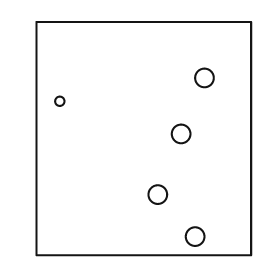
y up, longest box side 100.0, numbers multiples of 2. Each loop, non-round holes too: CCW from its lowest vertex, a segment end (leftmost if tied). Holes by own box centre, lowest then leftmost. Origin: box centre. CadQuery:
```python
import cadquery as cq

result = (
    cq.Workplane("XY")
    .moveTo(-46.0, -50.0)
    .lineTo(46.0, -50.0)
    .lineTo(46.0, 50.0)
    .lineTo(-46.0, 50.0)
    .close()
    .moveTo(22.0, -42.0)
    .circle(4.0)
    .moveTo(6.0, -24.0)
    .circle(4.0)
    .moveTo(16.0, 2.0)
    .circle(4.0)
    .moveTo(-36.0, 16.0)
    .circle(2.0)
    .moveTo(26.0, 26.0)
    .circle(4.0)
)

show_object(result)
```